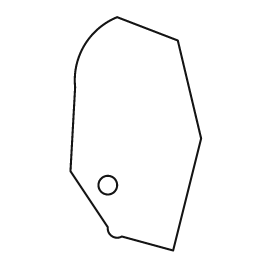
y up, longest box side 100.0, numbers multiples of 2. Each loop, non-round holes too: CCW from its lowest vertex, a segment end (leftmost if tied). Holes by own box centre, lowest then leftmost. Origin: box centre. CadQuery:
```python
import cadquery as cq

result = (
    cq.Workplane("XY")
    .moveTo(16.0, -50.0)
    .lineTo(28.0, -2.0)
    .lineTo(18.0, 40.0)
    .lineTo(-8.0, 50.0)
    .threePointArc((-22.0, 38.0), (-26.0, 20.0))
    .lineTo(-28.0, -16.0)
    .lineTo(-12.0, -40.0)
    .threePointArc((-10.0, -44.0), (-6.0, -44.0))
    .close()
    .moveTo(-12.0, -22.0)
    .circle(4.0)
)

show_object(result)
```